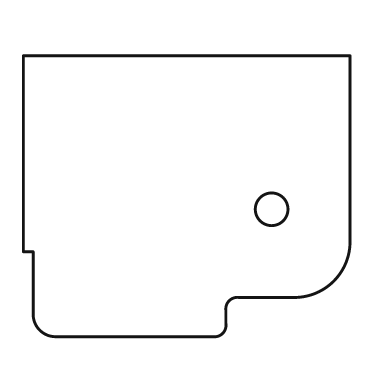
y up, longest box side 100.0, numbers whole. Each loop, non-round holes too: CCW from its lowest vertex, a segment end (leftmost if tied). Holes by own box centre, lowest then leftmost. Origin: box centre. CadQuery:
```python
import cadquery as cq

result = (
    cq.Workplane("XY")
    .moveTo(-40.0, -43.0)
    .lineTo(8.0, -43.0)
    .threePointArc((11.0, -42.0), (12.0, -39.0))
    .lineTo(12.0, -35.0)
    .threePointArc((13.0, -32.0), (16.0, -31.0))
    .lineTo(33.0, -31.0)
    .threePointArc((45.0, -26.0), (50.0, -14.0))
    .lineTo(50.0, 43.0)
    .lineTo(-50.0, 43.0)
    .lineTo(-50.0, -17.0)
    .lineTo(-47.0, -17.0)
    .lineTo(-47.0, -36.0)
    .threePointArc((-45.0, -41.0), (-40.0, -43.0))
    .close()
    .moveTo(26.0, -4.0)
    .circle(5.0)
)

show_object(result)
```